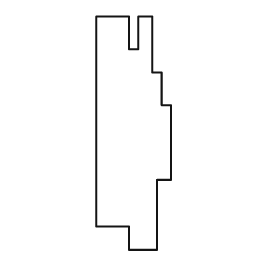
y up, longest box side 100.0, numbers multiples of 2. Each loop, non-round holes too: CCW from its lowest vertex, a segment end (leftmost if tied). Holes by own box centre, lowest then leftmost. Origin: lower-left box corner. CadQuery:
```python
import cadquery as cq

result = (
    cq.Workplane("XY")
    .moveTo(14.0, 0.0)
    .lineTo(26.0, 0.0)
    .lineTo(26.0, 30.0)
    .lineTo(32.0, 30.0)
    .lineTo(32.0, 62.0)
    .lineTo(28.0, 62.0)
    .lineTo(28.0, 76.0)
    .lineTo(24.0, 76.0)
    .lineTo(24.0, 100.0)
    .lineTo(18.0, 100.0)
    .lineTo(18.0, 86.0)
    .lineTo(14.0, 86.0)
    .lineTo(14.0, 100.0)
    .lineTo(0.0, 100.0)
    .lineTo(0.0, 10.0)
    .lineTo(14.0, 10.0)
    .close()
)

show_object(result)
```